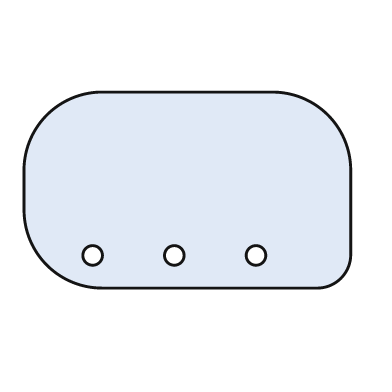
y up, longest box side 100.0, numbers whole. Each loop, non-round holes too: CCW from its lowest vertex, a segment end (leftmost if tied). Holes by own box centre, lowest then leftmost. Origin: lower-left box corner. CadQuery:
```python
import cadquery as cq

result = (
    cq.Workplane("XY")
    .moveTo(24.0, 0.0)
    .lineTo(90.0, 0.0)
    .threePointArc((97.0, 3.0), (100.0, 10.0))
    .lineTo(100.0, 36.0)
    .threePointArc((93.0, 53.0), (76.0, 60.0))
    .lineTo(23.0, 60.0)
    .threePointArc((7.0, 53.0), (0.0, 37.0))
    .lineTo(0.0, 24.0)
    .threePointArc((7.0, 7.0), (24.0, 0.0))
    .close()
    .moveTo(21.0, 10.0)
    .circle(3.0)
    .moveTo(46.0, 10.0)
    .circle(3.0)
    .moveTo(71.0, 10.0)
    .circle(3.0)
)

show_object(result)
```